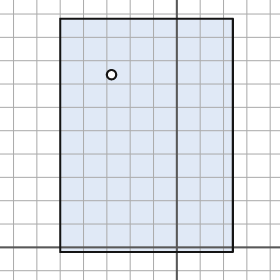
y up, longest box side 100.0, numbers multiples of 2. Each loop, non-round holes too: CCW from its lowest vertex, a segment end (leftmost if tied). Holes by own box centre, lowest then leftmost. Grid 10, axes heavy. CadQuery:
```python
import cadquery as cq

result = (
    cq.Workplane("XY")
    .moveTo(-50.0, -2.0)
    .lineTo(24.0, -2.0)
    .lineTo(24.0, 98.0)
    .lineTo(-50.0, 98.0)
    .close()
    .moveTo(-28.0, 74.0)
    .circle(2.0)
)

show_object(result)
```